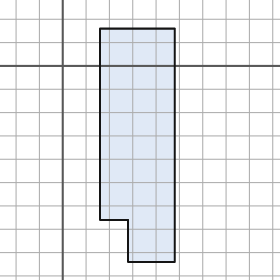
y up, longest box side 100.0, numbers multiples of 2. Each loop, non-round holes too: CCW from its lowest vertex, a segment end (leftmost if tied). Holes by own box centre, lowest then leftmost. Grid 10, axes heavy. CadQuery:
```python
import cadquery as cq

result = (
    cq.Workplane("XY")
    .moveTo(28.0, -84.0)
    .lineTo(48.0, -84.0)
    .lineTo(48.0, 16.0)
    .lineTo(16.0, 16.0)
    .lineTo(16.0, -66.0)
    .lineTo(28.0, -66.0)
    .close()
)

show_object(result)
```